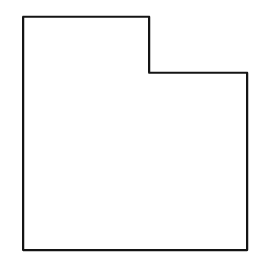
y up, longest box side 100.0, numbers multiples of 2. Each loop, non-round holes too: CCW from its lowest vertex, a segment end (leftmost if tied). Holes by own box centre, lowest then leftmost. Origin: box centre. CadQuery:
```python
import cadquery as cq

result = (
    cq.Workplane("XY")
    .moveTo(-48.0, -50.0)
    .lineTo(48.0, -50.0)
    .lineTo(48.0, 26.0)
    .lineTo(6.0, 26.0)
    .lineTo(6.0, 50.0)
    .lineTo(-48.0, 50.0)
    .close()
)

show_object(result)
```